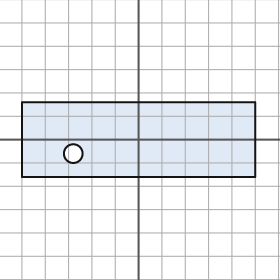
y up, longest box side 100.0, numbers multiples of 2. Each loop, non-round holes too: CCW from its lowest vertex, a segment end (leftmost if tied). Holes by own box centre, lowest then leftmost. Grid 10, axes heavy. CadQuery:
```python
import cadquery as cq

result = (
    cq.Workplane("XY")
    .moveTo(-50.0, -16.0)
    .lineTo(50.0, -16.0)
    .lineTo(50.0, 16.0)
    .lineTo(-50.0, 16.0)
    .close()
    .moveTo(-28.0, -6.0)
    .circle(4.0)
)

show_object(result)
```